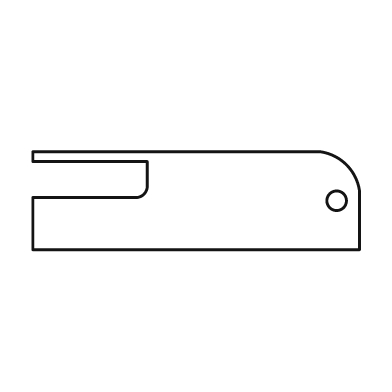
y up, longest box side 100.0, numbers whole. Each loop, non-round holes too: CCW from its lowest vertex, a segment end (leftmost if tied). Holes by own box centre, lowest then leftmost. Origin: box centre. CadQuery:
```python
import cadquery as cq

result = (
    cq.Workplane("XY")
    .moveTo(-50.0, -15.0)
    .lineTo(50.0, -15.0)
    .lineTo(50.0, 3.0)
    .threePointArc((46.0, 11.0), (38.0, 15.0))
    .lineTo(-50.0, 15.0)
    .lineTo(-50.0, 12.0)
    .lineTo(-15.0, 12.0)
    .lineTo(-15.0, 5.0)
    .threePointArc((-16.0, 2.0), (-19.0, 1.0))
    .lineTo(-50.0, 1.0)
    .close()
    .moveTo(43.0, 0.0)
    .circle(3.0)
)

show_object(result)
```